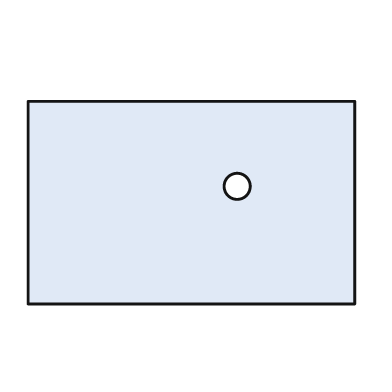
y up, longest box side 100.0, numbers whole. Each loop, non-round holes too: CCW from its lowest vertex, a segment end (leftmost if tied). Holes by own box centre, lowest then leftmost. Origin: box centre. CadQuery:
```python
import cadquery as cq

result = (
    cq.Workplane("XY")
    .moveTo(-50.0, -31.0)
    .lineTo(50.0, -31.0)
    .lineTo(50.0, 31.0)
    .lineTo(-50.0, 31.0)
    .close()
    .moveTo(14.0, 5.0)
    .circle(4.0)
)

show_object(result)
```